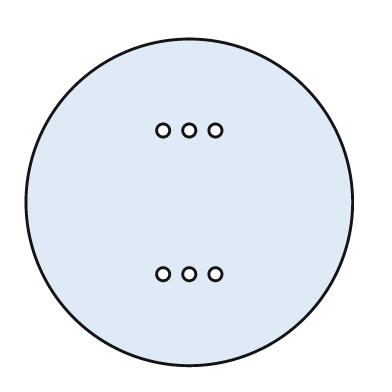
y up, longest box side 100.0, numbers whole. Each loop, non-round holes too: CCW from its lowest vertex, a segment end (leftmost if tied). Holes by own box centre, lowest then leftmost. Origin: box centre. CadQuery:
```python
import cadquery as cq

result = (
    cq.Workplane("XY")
    .moveTo(0.0, 0.0)
    .circle(50.0)
    .moveTo(-8.0, -22.0)
    .circle(2.0)
    .moveTo(0.0, -22.0)
    .circle(2.0)
    .moveTo(8.0, -22.0)
    .circle(2.0)
    .moveTo(-8.0, 22.0)
    .circle(2.0)
    .moveTo(0.0, 22.0)
    .circle(2.0)
    .moveTo(8.0, 22.0)
    .circle(2.0)
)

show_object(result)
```